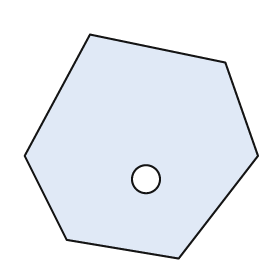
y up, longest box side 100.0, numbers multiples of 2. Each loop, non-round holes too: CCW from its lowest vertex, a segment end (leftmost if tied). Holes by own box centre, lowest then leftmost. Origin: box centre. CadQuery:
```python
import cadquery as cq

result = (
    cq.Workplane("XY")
    .moveTo(16.0, -48.0)
    .lineTo(50.0, -4.0)
    .lineTo(36.0, 36.0)
    .lineTo(-22.0, 48.0)
    .lineTo(-50.0, -4.0)
    .lineTo(-32.0, -40.0)
    .close()
    .moveTo(2.0, -14.0)
    .circle(6.0)
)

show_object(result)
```